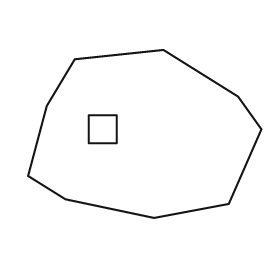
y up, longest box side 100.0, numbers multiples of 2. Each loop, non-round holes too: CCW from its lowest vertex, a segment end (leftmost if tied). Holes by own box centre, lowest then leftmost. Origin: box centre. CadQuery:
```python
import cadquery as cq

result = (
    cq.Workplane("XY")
    .moveTo(4.0, -36.0)
    .lineTo(36.0, -30.0)
    .lineTo(50.0, 2.0)
    .lineTo(40.0, 16.0)
    .lineTo(8.0, 36.0)
    .lineTo(-30.0, 32.0)
    .lineTo(-42.0, 12.0)
    .lineTo(-50.0, -18.0)
    .lineTo(-34.0, -28.0)
    .close()
    .moveTo(-24.0, -4.0)
    .lineTo(-12.0, -4.0)
    .lineTo(-12.0, 8.0)
    .lineTo(-24.0, 8.0)
    .close()
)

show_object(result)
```